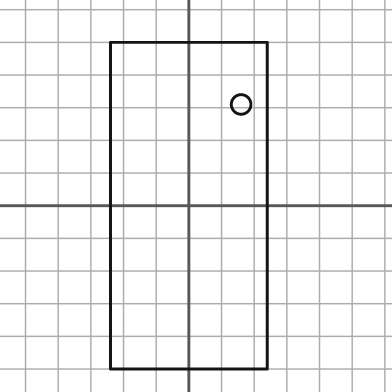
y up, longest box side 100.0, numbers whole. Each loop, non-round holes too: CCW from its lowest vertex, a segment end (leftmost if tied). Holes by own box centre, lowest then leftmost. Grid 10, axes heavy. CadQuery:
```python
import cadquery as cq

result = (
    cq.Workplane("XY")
    .moveTo(-24.0, -50.0)
    .lineTo(24.0, -50.0)
    .lineTo(24.0, 50.0)
    .lineTo(-24.0, 50.0)
    .close()
    .moveTo(16.0, 31.0)
    .circle(3.0)
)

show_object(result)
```